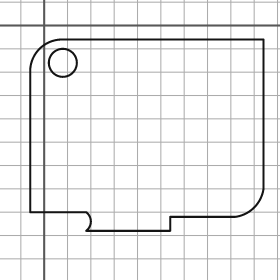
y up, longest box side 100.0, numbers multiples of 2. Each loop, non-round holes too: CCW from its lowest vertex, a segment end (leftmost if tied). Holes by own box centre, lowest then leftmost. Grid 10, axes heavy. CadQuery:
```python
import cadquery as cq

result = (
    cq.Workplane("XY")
    .moveTo(18.0, -88.0)
    .lineTo(54.0, -88.0)
    .lineTo(54.0, -82.0)
    .lineTo(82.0, -82.0)
    .threePointArc((90.0, -78.0), (94.0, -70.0))
    .lineTo(94.0, -6.0)
    .lineTo(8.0, -6.0)
    .threePointArc((-2.0, -10.0), (-6.0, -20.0))
    .lineTo(-6.0, -80.0)
    .lineTo(18.0, -80.0)
    .threePointArc((20.0, -84.0), (18.0, -88.0))
    .close()
    .moveTo(8.0, -16.0)
    .circle(6.0)
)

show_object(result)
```